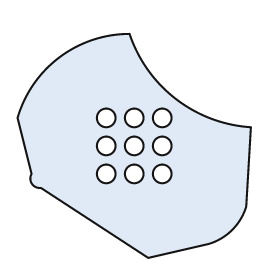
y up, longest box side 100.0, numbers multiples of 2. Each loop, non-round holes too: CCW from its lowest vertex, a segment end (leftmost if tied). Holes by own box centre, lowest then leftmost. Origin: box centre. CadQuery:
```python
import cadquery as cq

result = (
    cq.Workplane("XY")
    .moveTo(6.0, -48.0)
    .lineTo(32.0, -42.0)
    .threePointArc((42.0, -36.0), (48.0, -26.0))
    .lineTo(50.0, 8.0)
    .threePointArc((18.0, 20.0), (-2.0, 48.0))
    .threePointArc((-32.0, 38.0), (-50.0, 12.0))
    .lineTo(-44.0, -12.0)
    .threePointArc((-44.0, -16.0), (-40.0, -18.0))
    .close()
    .moveTo(-12.0, -12.0)
    .circle(4.0)
    .moveTo(0.0, -12.0)
    .circle(4.0)
    .moveTo(12.0, -12.0)
    .circle(4.0)
    .moveTo(-12.0, 0.0)
    .circle(4.0)
    .moveTo(0.0, 0.0)
    .circle(4.0)
    .moveTo(12.0, 0.0)
    .circle(4.0)
    .moveTo(-12.0, 12.0)
    .circle(4.0)
    .moveTo(0.0, 12.0)
    .circle(4.0)
    .moveTo(12.0, 12.0)
    .circle(4.0)
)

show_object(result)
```